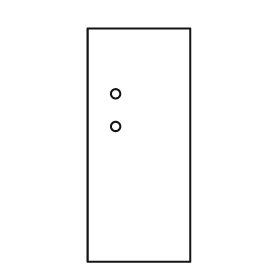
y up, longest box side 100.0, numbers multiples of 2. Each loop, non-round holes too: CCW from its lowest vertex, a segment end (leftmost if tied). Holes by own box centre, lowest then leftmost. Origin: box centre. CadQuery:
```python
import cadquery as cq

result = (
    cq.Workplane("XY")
    .moveTo(-22.0, -50.0)
    .lineTo(22.0, -50.0)
    .lineTo(22.0, 50.0)
    .lineTo(-22.0, 50.0)
    .close()
    .moveTo(-10.0, 8.0)
    .circle(2.0)
    .moveTo(-10.0, 22.0)
    .circle(2.0)
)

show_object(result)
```